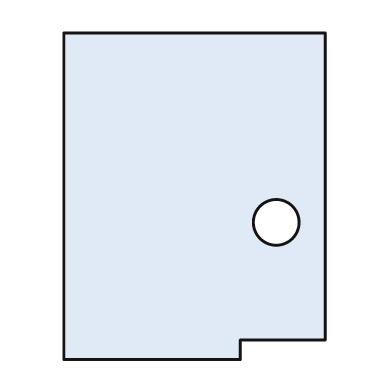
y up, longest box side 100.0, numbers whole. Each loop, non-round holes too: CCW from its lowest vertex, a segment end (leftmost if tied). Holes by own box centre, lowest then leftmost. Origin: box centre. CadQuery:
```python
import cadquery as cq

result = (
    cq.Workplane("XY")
    .moveTo(-40.0, -50.0)
    .lineTo(14.0, -50.0)
    .lineTo(14.0, -44.0)
    .lineTo(40.0, -44.0)
    .lineTo(40.0, 50.0)
    .lineTo(-40.0, 50.0)
    .close()
    .moveTo(25.0, -8.0)
    .circle(7.0)
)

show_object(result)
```